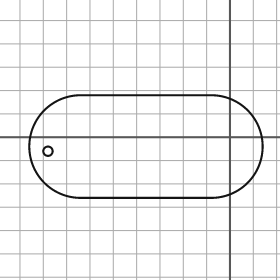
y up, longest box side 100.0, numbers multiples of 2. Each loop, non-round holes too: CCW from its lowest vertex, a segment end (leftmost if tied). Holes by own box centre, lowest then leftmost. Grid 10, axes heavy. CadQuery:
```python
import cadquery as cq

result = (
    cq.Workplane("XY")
    .moveTo(-64.0, -26.0)
    .lineTo(-8.0, -26.0)
    .threePointArc((14.0, -4.0), (-8.0, 18.0))
    .lineTo(-64.0, 18.0)
    .threePointArc((-86.0, -4.0), (-64.0, -26.0))
    .close()
    .moveTo(-78.0, -6.0)
    .circle(2.0)
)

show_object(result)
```